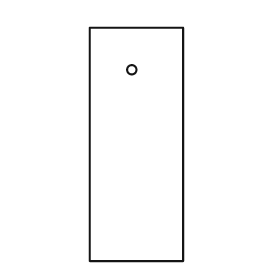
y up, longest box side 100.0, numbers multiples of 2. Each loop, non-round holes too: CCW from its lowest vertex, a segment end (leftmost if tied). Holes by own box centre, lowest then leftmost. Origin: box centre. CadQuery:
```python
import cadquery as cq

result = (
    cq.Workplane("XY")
    .moveTo(-20.0, -50.0)
    .lineTo(20.0, -50.0)
    .lineTo(20.0, 50.0)
    .lineTo(-20.0, 50.0)
    .close()
    .moveTo(-2.0, 32.0)
    .circle(2.0)
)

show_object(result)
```